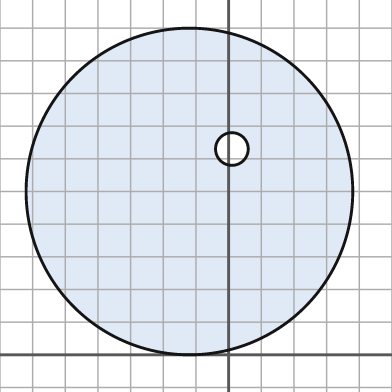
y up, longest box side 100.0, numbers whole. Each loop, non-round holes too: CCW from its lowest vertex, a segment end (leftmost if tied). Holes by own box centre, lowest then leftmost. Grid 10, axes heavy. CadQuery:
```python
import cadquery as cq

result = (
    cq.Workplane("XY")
    .moveTo(-12.0, 50.0)
    .circle(50.0)
    .moveTo(1.0, 63.0)
    .circle(5.0)
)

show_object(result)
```